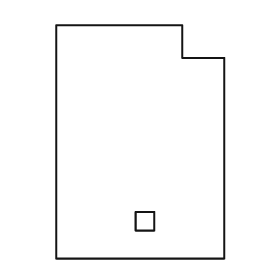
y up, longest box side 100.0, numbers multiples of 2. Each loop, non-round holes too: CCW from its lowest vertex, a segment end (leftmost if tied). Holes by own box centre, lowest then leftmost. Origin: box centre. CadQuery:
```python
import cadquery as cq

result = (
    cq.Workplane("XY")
    .moveTo(-36.0, -50.0)
    .lineTo(36.0, -50.0)
    .lineTo(36.0, 36.0)
    .lineTo(18.0, 36.0)
    .lineTo(18.0, 50.0)
    .lineTo(-36.0, 50.0)
    .close()
    .moveTo(-2.0, -38.0)
    .lineTo(6.0, -38.0)
    .lineTo(6.0, -30.0)
    .lineTo(-2.0, -30.0)
    .close()
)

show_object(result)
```